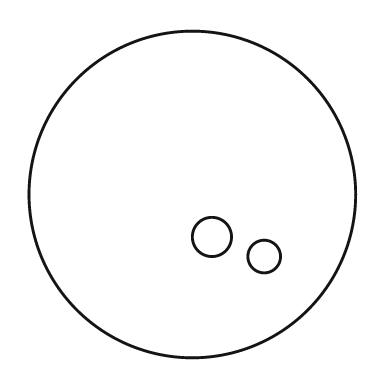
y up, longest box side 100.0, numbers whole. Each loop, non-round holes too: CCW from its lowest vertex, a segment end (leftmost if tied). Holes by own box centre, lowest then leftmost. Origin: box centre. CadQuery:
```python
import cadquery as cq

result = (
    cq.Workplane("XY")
    .moveTo(0.0, 0.0)
    .circle(50.0)
    .moveTo(22.0, -19.0)
    .circle(5.0)
    .moveTo(6.0, -13.0)
    .circle(6.0)
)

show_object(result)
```